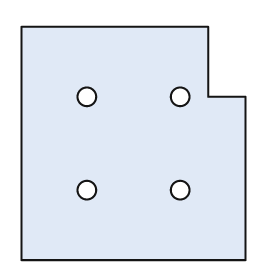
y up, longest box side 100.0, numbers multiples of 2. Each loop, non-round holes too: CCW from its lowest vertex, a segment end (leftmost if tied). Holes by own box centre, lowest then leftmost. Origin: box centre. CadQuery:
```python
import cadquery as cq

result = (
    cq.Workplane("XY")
    .moveTo(-48.0, -50.0)
    .lineTo(48.0, -50.0)
    .lineTo(48.0, 20.0)
    .lineTo(32.0, 20.0)
    .lineTo(32.0, 50.0)
    .lineTo(-48.0, 50.0)
    .close()
    .moveTo(-20.0, -20.0)
    .circle(4.0)
    .moveTo(20.0, -20.0)
    .circle(4.0)
    .moveTo(-20.0, 20.0)
    .circle(4.0)
    .moveTo(20.0, 20.0)
    .circle(4.0)
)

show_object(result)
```